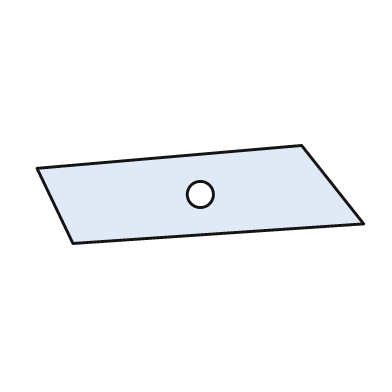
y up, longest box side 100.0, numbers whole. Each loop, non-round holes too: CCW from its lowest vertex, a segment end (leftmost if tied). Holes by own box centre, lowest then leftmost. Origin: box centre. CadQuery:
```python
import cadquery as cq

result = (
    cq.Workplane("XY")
    .moveTo(-39.0, -15.0)
    .lineTo(50.0, -9.0)
    .lineTo(31.0, 15.0)
    .lineTo(-50.0, 8.0)
    .close()
    .moveTo(0.0, 0.0)
    .circle(4.0)
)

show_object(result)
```